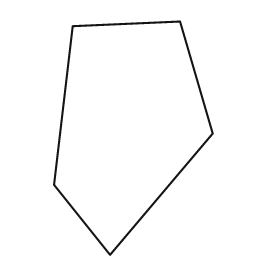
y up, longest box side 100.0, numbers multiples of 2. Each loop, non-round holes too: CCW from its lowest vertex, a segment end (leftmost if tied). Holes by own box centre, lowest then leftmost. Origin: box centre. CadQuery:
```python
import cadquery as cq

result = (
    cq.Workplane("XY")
    .moveTo(-10.0, -50.0)
    .lineTo(34.0, 2.0)
    .lineTo(20.0, 50.0)
    .lineTo(-26.0, 48.0)
    .lineTo(-34.0, -20.0)
    .close()
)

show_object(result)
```